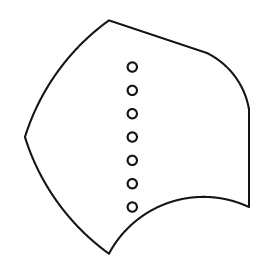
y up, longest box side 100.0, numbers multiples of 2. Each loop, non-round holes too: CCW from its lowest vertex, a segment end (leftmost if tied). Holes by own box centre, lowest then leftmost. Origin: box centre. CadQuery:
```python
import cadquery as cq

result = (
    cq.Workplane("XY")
    .moveTo(-12.0, -50.0)
    .threePointArc((14.0, -28.0), (48.0, -30.0))
    .lineTo(48.0, 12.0)
    .threePointArc((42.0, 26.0), (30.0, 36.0))
    .lineTo(-12.0, 50.0)
    .threePointArc((-34.0, 28.0), (-48.0, 0.0))
    .threePointArc((-34.0, -28.0), (-12.0, -50.0))
    .close()
    .moveTo(-2.0, -30.0)
    .circle(2.0)
    .moveTo(-2.0, -20.0)
    .circle(2.0)
    .moveTo(-2.0, -10.0)
    .circle(2.0)
    .moveTo(-2.0, 0.0)
    .circle(2.0)
    .moveTo(-2.0, 10.0)
    .circle(2.0)
    .moveTo(-2.0, 20.0)
    .circle(2.0)
    .moveTo(-2.0, 30.0)
    .circle(2.0)
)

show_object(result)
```